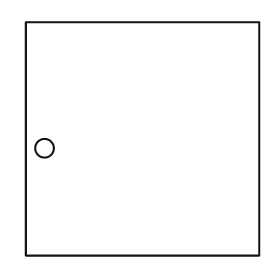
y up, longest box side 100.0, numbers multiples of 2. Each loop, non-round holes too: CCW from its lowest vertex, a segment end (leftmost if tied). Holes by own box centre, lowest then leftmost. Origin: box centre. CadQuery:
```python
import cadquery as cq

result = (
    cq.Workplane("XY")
    .moveTo(-50.0, -50.0)
    .lineTo(50.0, -50.0)
    .lineTo(50.0, 50.0)
    .lineTo(-50.0, 50.0)
    .close()
    .moveTo(-42.0, -4.0)
    .circle(4.0)
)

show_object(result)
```